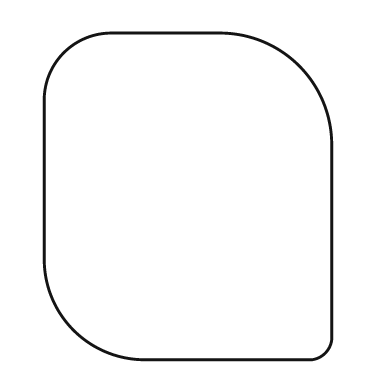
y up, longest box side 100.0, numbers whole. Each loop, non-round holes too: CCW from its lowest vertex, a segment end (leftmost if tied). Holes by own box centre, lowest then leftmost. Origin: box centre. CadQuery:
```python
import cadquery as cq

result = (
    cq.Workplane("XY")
    .moveTo(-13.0, -50.0)
    .lineTo(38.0, -50.0)
    .threePointArc((42.0, -48.0), (44.0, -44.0))
    .lineTo(44.0, 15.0)
    .threePointArc((34.0, 40.0), (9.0, 50.0))
    .lineTo(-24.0, 50.0)
    .threePointArc((-38.0, 44.0), (-44.0, 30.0))
    .lineTo(-44.0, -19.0)
    .threePointArc((-35.0, -41.0), (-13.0, -50.0))
    .close()
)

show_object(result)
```